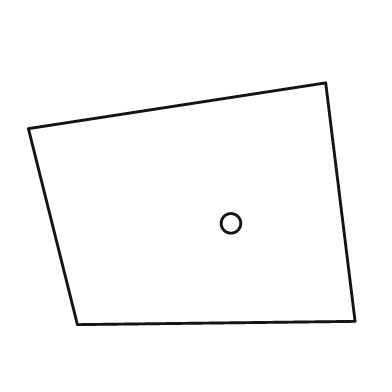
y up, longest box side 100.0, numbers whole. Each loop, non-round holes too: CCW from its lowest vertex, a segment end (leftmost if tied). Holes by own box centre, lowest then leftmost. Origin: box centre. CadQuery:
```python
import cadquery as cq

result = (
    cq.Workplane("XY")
    .moveTo(-35.0, -37.0)
    .lineTo(50.0, -36.0)
    .lineTo(41.0, 37.0)
    .lineTo(-50.0, 23.0)
    .close()
    .moveTo(12.0, -6.0)
    .circle(3.0)
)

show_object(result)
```